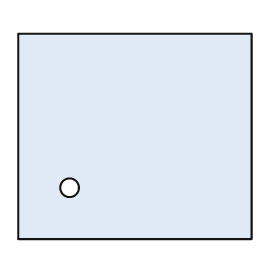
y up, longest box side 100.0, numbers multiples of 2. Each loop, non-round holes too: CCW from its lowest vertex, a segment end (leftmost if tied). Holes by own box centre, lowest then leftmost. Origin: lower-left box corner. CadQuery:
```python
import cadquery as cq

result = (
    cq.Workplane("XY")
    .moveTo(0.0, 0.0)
    .lineTo(100.0, 0.0)
    .lineTo(100.0, 88.0)
    .lineTo(0.0, 88.0)
    .close()
    .moveTo(22.0, 22.0)
    .circle(4.0)
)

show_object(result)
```